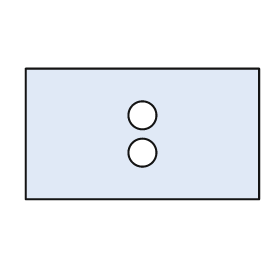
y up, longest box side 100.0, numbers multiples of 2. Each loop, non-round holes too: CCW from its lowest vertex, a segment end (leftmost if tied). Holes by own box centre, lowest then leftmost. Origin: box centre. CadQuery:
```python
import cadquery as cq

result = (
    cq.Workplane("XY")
    .moveTo(-50.0, -28.0)
    .lineTo(50.0, -28.0)
    .lineTo(50.0, 28.0)
    .lineTo(-50.0, 28.0)
    .close()
    .moveTo(0.0, -8.0)
    .circle(6.0)
    .moveTo(0.0, 8.0)
    .circle(6.0)
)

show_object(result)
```